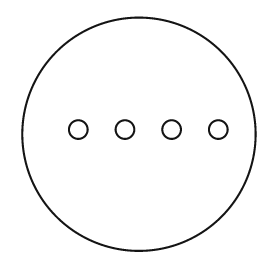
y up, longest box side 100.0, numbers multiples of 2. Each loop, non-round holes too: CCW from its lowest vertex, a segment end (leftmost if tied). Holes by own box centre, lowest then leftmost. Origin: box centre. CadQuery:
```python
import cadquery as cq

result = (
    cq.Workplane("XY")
    .moveTo(0.0, 0.0)
    .circle(50.0)
    .moveTo(-26.0, 2.0)
    .circle(4.0)
    .moveTo(-6.0, 2.0)
    .circle(4.0)
    .moveTo(14.0, 2.0)
    .circle(4.0)
    .moveTo(34.0, 2.0)
    .circle(4.0)
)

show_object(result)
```